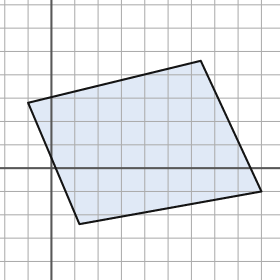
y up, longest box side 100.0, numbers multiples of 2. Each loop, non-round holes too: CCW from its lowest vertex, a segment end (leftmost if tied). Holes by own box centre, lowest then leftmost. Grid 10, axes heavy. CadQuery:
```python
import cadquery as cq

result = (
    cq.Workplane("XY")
    .moveTo(12.0, -24.0)
    .lineTo(90.0, -10.0)
    .lineTo(64.0, 46.0)
    .lineTo(-10.0, 28.0)
    .close()
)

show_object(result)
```